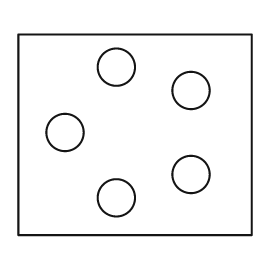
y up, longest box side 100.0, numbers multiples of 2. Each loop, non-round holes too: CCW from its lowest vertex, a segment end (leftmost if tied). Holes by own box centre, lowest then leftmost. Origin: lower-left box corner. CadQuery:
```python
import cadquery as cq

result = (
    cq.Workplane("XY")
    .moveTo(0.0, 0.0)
    .lineTo(100.0, 0.0)
    .lineTo(100.0, 86.0)
    .lineTo(0.0, 86.0)
    .close()
    .moveTo(42.0, 16.0)
    .circle(8.0)
    .moveTo(74.0, 26.0)
    .circle(8.0)
    .moveTo(20.0, 44.0)
    .circle(8.0)
    .moveTo(74.0, 62.0)
    .circle(8.0)
    .moveTo(42.0, 72.0)
    .circle(8.0)
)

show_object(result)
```